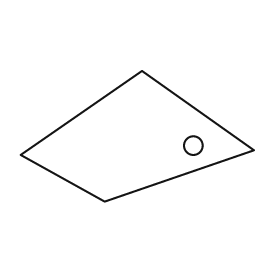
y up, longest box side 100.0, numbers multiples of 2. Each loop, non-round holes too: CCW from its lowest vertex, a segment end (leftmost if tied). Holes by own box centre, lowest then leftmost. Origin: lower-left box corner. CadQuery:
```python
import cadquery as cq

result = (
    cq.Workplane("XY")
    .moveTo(36.0, 0.0)
    .lineTo(100.0, 22.0)
    .lineTo(52.0, 56.0)
    .lineTo(0.0, 20.0)
    .close()
    .moveTo(74.0, 24.0)
    .circle(4.0)
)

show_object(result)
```